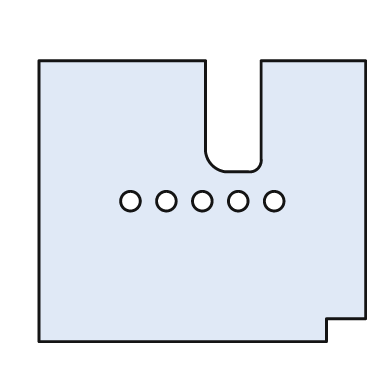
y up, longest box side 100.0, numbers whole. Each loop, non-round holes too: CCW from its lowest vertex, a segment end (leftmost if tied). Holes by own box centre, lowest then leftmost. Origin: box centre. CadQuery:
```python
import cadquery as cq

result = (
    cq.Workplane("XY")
    .moveTo(-50.0, -43.0)
    .lineTo(38.0, -43.0)
    .lineTo(38.0, -36.0)
    .lineTo(50.0, -36.0)
    .lineTo(50.0, 43.0)
    .lineTo(18.0, 43.0)
    .lineTo(18.0, 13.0)
    .threePointArc((17.0, 10.0), (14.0, 9.0))
    .lineTo(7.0, 9.0)
    .threePointArc((3.0, 11.0), (1.0, 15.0))
    .lineTo(1.0, 43.0)
    .lineTo(-50.0, 43.0)
    .close()
    .moveTo(-22.0, 0.0)
    .circle(3.0)
    .moveTo(-11.0, 0.0)
    .circle(3.0)
    .moveTo(0.0, 0.0)
    .circle(3.0)
    .moveTo(11.0, 0.0)
    .circle(3.0)
    .moveTo(22.0, 0.0)
    .circle(3.0)
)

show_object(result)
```